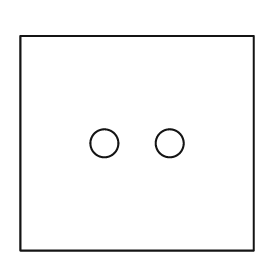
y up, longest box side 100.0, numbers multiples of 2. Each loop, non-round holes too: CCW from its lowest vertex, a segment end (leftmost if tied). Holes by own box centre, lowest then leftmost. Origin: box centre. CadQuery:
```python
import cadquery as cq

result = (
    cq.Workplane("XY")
    .moveTo(-50.0, -46.0)
    .lineTo(50.0, -46.0)
    .lineTo(50.0, 46.0)
    .lineTo(-50.0, 46.0)
    .close()
    .moveTo(-14.0, 0.0)
    .circle(6.0)
    .moveTo(14.0, 0.0)
    .circle(6.0)
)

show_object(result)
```